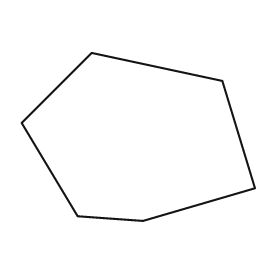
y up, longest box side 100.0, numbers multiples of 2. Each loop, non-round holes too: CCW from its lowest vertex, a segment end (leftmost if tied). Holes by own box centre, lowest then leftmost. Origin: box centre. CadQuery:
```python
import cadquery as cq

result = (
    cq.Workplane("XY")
    .moveTo(2.0, -36.0)
    .lineTo(50.0, -22.0)
    .lineTo(36.0, 24.0)
    .lineTo(-20.0, 36.0)
    .lineTo(-50.0, 6.0)
    .lineTo(-26.0, -34.0)
    .close()
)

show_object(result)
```